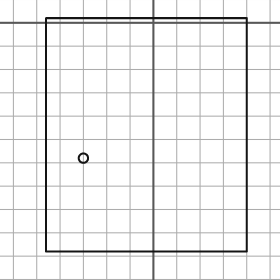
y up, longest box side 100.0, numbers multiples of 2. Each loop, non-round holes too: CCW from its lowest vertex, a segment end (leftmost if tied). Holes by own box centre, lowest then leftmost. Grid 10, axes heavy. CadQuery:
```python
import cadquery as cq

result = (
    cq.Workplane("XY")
    .moveTo(-46.0, -98.0)
    .lineTo(40.0, -98.0)
    .lineTo(40.0, 2.0)
    .lineTo(-46.0, 2.0)
    .close()
    .moveTo(-30.0, -58.0)
    .circle(2.0)
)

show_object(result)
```